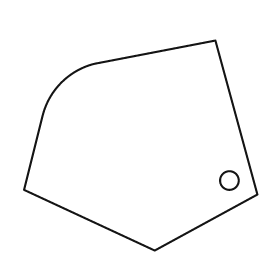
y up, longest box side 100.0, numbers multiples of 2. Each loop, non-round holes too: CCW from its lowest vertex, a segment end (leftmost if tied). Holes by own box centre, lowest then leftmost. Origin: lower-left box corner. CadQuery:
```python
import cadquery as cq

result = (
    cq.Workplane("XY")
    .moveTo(56.0, 0.0)
    .lineTo(100.0, 24.0)
    .lineTo(82.0, 90.0)
    .lineTo(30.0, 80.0)
    .threePointArc((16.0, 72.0), (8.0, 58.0))
    .lineTo(0.0, 26.0)
    .close()
    .moveTo(88.0, 30.0)
    .circle(4.0)
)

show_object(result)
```